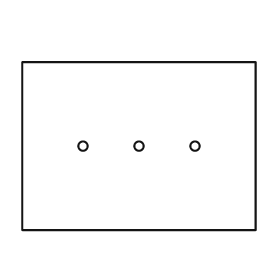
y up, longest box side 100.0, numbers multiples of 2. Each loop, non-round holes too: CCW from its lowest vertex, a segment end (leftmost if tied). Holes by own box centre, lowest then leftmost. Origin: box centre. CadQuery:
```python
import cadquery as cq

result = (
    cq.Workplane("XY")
    .moveTo(-50.0, -36.0)
    .lineTo(50.0, -36.0)
    .lineTo(50.0, 36.0)
    .lineTo(-50.0, 36.0)
    .close()
    .moveTo(-24.0, 0.0)
    .circle(2.0)
    .moveTo(0.0, 0.0)
    .circle(2.0)
    .moveTo(24.0, 0.0)
    .circle(2.0)
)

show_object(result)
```